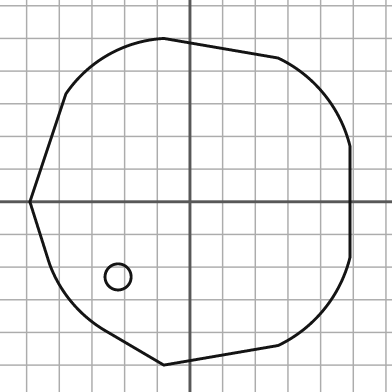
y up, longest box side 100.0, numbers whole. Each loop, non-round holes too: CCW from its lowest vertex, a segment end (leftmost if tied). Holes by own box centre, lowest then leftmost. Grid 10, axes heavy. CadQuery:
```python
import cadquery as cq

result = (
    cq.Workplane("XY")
    .moveTo(-8.0, -50.0)
    .lineTo(27.0, -44.0)
    .threePointArc((41.0, -33.0), (49.0, -17.0))
    .lineTo(49.0, 17.0)
    .threePointArc((41.0, 33.0), (27.0, 44.0))
    .lineTo(-8.0, 50.0)
    .threePointArc((-25.0, 45.0), (-38.0, 33.0))
    .lineTo(-49.0, 0.0)
    .lineTo(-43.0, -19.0)
    .threePointArc((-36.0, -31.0), (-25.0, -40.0))
    .close()
    .moveTo(-22.0, -23.0)
    .circle(4.0)
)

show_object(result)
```